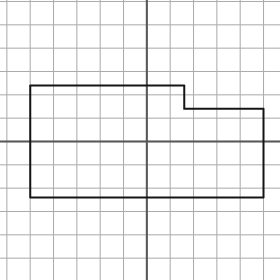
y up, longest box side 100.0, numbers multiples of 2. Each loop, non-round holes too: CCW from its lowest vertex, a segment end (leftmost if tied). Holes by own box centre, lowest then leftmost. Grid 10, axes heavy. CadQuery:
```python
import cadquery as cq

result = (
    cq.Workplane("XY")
    .moveTo(-50.0, -24.0)
    .lineTo(50.0, -24.0)
    .lineTo(50.0, 14.0)
    .lineTo(16.0, 14.0)
    .lineTo(16.0, 24.0)
    .lineTo(-50.0, 24.0)
    .close()
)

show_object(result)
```